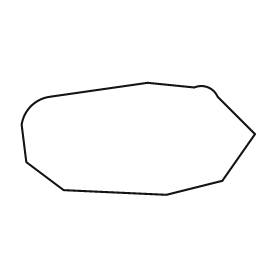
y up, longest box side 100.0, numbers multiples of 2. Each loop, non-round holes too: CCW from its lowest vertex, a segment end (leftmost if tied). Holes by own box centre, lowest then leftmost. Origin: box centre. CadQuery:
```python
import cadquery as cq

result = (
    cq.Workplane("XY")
    .moveTo(12.0, -24.0)
    .lineTo(36.0, -18.0)
    .lineTo(50.0, 2.0)
    .lineTo(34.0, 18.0)
    .threePointArc((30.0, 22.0), (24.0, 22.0))
    .lineTo(4.0, 24.0)
    .lineTo(-38.0, 18.0)
    .threePointArc((-46.0, 14.0), (-50.0, 6.0))
    .lineTo(-48.0, -10.0)
    .lineTo(-32.0, -22.0)
    .close()
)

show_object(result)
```